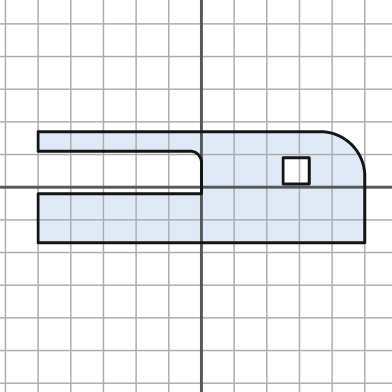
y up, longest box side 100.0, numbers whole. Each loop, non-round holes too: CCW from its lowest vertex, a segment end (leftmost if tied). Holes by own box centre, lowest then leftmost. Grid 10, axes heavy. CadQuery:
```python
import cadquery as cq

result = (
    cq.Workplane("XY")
    .moveTo(-50.0, -17.0)
    .lineTo(50.0, -17.0)
    .lineTo(50.0, 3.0)
    .threePointArc((46.0, 13.0), (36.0, 17.0))
    .lineTo(-50.0, 17.0)
    .lineTo(-50.0, 11.0)
    .lineTo(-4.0, 11.0)
    .threePointArc((-1.0, 10.0), (0.0, 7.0))
    .lineTo(0.0, -2.0)
    .lineTo(-50.0, -2.0)
    .close()
    .moveTo(25.0, 1.0)
    .lineTo(33.0, 1.0)
    .lineTo(33.0, 9.0)
    .lineTo(25.0, 9.0)
    .close()
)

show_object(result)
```